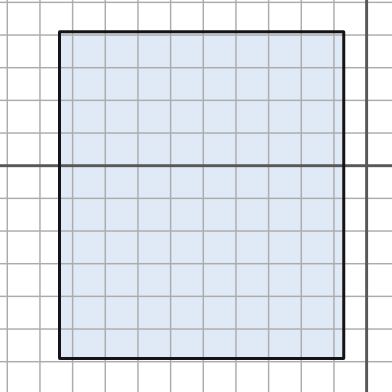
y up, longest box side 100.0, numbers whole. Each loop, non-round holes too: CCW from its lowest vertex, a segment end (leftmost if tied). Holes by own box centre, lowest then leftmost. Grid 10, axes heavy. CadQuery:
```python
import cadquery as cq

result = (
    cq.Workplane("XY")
    .moveTo(-94.0, -59.0)
    .lineTo(-7.0, -59.0)
    .lineTo(-7.0, 41.0)
    .lineTo(-94.0, 41.0)
    .close()
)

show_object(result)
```